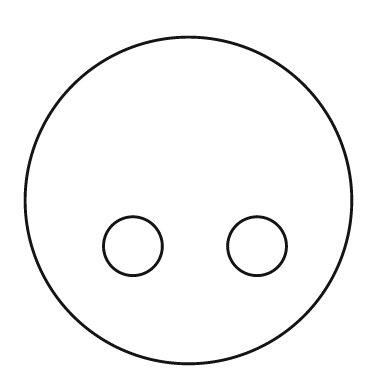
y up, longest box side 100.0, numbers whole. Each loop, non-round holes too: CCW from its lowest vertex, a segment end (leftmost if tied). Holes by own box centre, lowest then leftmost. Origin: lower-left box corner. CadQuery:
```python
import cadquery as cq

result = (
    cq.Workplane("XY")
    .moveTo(50.0, 50.0)
    .circle(50.0)
    .moveTo(33.0, 36.0)
    .circle(9.0)
    .moveTo(71.0, 36.0)
    .circle(9.0)
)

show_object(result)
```